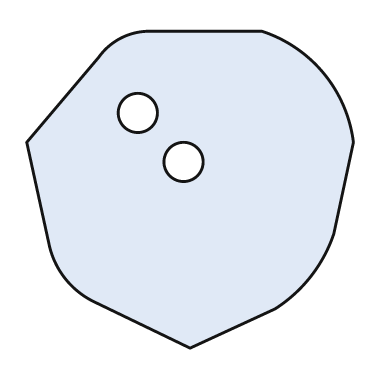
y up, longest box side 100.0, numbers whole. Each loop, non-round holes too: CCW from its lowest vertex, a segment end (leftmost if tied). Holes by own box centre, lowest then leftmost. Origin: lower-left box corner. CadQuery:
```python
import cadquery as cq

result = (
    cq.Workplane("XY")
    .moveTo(50.0, 0.0)
    .lineTo(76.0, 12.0)
    .threePointArc((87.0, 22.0), (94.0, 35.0))
    .lineTo(100.0, 63.0)
    .threePointArc((91.0, 84.0), (72.0, 97.0))
    .lineTo(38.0, 97.0)
    .threePointArc((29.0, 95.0), (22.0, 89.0))
    .lineTo(0.0, 63.0)
    .lineTo(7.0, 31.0)
    .threePointArc((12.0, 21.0), (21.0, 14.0))
    .close()
    .moveTo(48.0, 57.0)
    .circle(6.0)
    .moveTo(34.0, 72.0)
    .circle(6.0)
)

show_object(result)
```